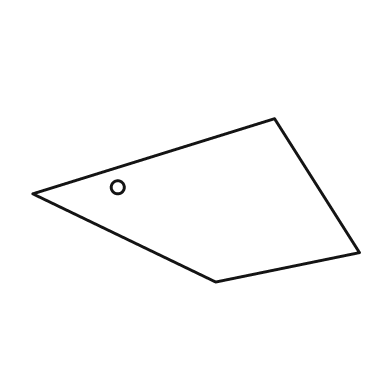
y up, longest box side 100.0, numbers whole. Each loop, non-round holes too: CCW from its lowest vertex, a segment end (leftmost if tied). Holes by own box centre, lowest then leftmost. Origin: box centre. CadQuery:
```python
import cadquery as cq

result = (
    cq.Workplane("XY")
    .moveTo(6.0, -25.0)
    .lineTo(50.0, -16.0)
    .lineTo(24.0, 25.0)
    .lineTo(-50.0, 2.0)
    .close()
    .moveTo(-24.0, 4.0)
    .circle(2.0)
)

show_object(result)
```